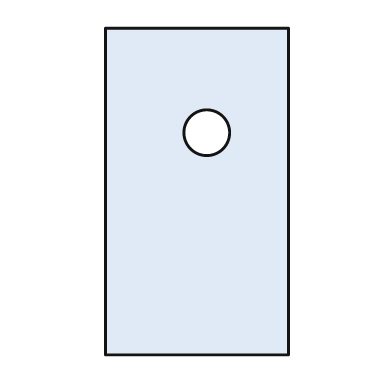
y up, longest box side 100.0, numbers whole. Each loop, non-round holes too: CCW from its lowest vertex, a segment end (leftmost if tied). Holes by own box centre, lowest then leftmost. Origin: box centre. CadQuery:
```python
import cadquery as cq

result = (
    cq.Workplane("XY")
    .moveTo(-28.0, -50.0)
    .lineTo(28.0, -50.0)
    .lineTo(28.0, 50.0)
    .lineTo(-28.0, 50.0)
    .close()
    .moveTo(3.0, 18.0)
    .circle(7.0)
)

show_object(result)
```